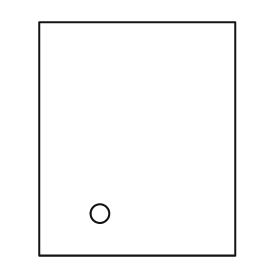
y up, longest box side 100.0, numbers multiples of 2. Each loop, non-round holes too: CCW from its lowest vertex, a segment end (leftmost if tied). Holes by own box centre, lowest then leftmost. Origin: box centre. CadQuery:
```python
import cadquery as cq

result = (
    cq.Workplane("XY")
    .moveTo(-42.0, -50.0)
    .lineTo(42.0, -50.0)
    .lineTo(42.0, 50.0)
    .lineTo(-42.0, 50.0)
    .close()
    .moveTo(-16.0, -32.0)
    .circle(4.0)
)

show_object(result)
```